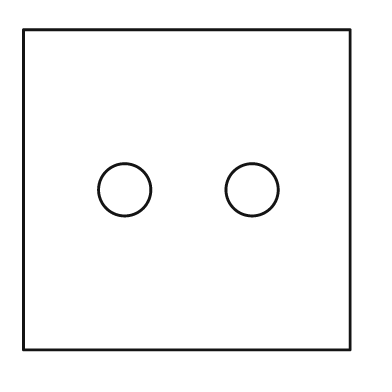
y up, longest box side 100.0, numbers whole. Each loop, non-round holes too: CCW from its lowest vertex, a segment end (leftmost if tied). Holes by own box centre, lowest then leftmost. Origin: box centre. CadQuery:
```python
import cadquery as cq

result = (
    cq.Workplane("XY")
    .moveTo(-50.0, -49.0)
    .lineTo(50.0, -49.0)
    .lineTo(50.0, 49.0)
    .lineTo(-50.0, 49.0)
    .close()
    .moveTo(-19.0, 0.0)
    .circle(8.0)
    .moveTo(20.0, 0.0)
    .circle(8.0)
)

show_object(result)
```